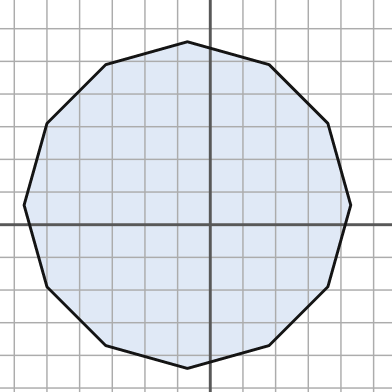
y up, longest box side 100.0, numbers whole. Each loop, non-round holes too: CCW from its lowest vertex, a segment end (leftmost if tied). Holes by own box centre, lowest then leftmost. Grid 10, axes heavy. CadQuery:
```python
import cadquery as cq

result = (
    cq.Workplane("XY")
    .moveTo(-7.0, -44.0)
    .lineTo(18.0, -37.0)
    .lineTo(36.0, -19.0)
    .lineTo(43.0, 6.0)
    .lineTo(36.0, 31.0)
    .lineTo(18.0, 49.0)
    .lineTo(-7.0, 56.0)
    .lineTo(-32.0, 49.0)
    .lineTo(-50.0, 31.0)
    .lineTo(-57.0, 6.0)
    .lineTo(-50.0, -19.0)
    .lineTo(-32.0, -37.0)
    .close()
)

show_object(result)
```